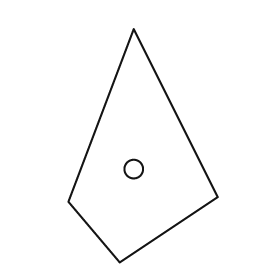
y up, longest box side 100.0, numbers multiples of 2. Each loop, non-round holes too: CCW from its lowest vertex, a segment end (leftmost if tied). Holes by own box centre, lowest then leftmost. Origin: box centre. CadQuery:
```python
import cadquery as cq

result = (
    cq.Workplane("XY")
    .moveTo(-10.0, -50.0)
    .lineTo(32.0, -22.0)
    .lineTo(-4.0, 50.0)
    .lineTo(-32.0, -24.0)
    .close()
    .moveTo(-4.0, -10.0)
    .circle(4.0)
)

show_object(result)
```